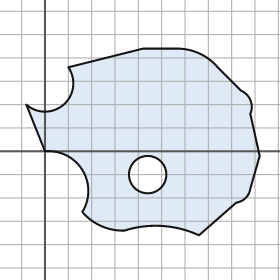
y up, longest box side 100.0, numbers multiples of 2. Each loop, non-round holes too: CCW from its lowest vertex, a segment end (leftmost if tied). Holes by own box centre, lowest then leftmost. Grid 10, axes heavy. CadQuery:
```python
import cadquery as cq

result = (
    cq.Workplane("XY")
    .moveTo(66.0, -36.0)
    .lineTo(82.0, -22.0)
    .threePointArc((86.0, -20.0), (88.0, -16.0))
    .lineTo(92.0, -2.0)
    .lineTo(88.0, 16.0)
    .threePointArc((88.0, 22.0), (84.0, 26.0))
    .lineTo(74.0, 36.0)
    .threePointArc((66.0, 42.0), (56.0, 44.0))
    .lineTo(42.0, 44.0)
    .lineTo(10.0, 36.0)
    .threePointArc((8.0, 20.0), (-8.0, 20.0))
    .lineTo(0.0, 0.0)
    .threePointArc((16.0, -8.0), (16.0, -26.0))
    .threePointArc((24.0, -32.0), (34.0, -34.0))
    .threePointArc((50.0, -32.0), (66.0, -36.0))
    .close()
    .moveTo(44.0, -10.0)
    .circle(8.0)
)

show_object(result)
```